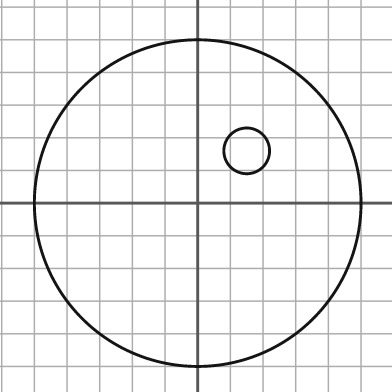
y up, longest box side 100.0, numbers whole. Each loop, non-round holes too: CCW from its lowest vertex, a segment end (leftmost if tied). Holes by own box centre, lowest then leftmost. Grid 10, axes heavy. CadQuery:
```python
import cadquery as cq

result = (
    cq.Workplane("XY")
    .moveTo(0.0, 0.0)
    .circle(50.0)
    .moveTo(15.0, 16.0)
    .circle(7.0)
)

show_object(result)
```